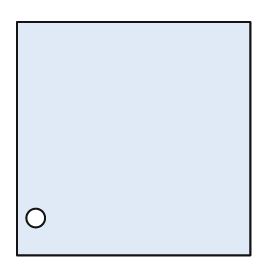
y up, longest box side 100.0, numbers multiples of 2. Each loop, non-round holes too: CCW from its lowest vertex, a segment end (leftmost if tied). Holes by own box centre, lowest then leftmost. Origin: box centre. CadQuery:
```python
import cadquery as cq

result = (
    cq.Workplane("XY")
    .moveTo(-50.0, -50.0)
    .lineTo(50.0, -50.0)
    .lineTo(50.0, 50.0)
    .lineTo(-50.0, 50.0)
    .close()
    .moveTo(-42.0, -34.0)
    .circle(4.0)
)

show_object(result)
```